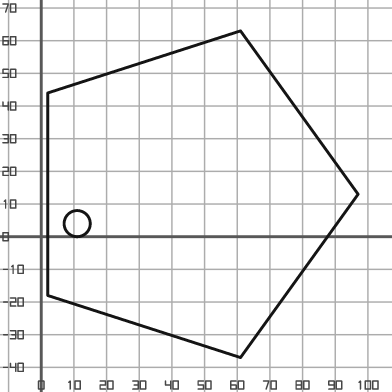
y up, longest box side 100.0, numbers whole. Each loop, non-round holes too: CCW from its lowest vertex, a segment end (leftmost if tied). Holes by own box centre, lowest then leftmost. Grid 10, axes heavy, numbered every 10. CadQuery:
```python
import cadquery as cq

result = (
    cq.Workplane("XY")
    .moveTo(61.0, -37.0)
    .lineTo(97.0, 13.0)
    .lineTo(61.0, 63.0)
    .lineTo(2.0, 44.0)
    .lineTo(2.0, -18.0)
    .close()
    .moveTo(11.0, 4.0)
    .circle(4.0)
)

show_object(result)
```